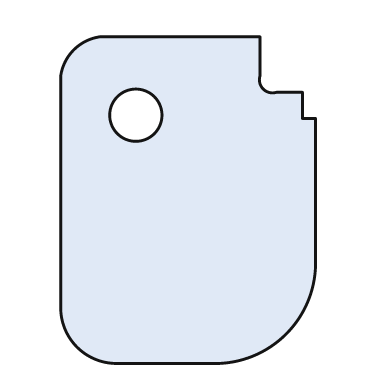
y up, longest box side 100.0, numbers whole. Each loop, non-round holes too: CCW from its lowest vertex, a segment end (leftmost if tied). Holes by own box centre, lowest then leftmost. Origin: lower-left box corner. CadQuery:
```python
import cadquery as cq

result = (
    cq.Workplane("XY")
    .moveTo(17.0, 0.0)
    .lineTo(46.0, 0.0)
    .threePointArc((69.0, 9.0), (78.0, 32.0))
    .lineTo(78.0, 75.0)
    .lineTo(74.0, 75.0)
    .lineTo(74.0, 83.0)
    .lineTo(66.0, 83.0)
    .threePointArc((62.0, 84.0), (61.0, 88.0))
    .lineTo(61.0, 100.0)
    .lineTo(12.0, 100.0)
    .threePointArc((4.0, 96.0), (0.0, 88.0))
    .lineTo(0.0, 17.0)
    .threePointArc((5.0, 5.0), (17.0, 0.0))
    .close()
    .moveTo(23.0, 76.0)
    .circle(8.0)
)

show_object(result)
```